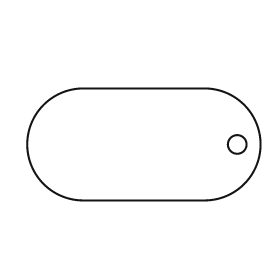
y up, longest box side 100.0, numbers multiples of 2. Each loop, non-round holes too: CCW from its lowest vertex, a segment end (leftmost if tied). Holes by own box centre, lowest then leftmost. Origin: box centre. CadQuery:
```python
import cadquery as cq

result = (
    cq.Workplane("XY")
    .moveTo(-26.0, -24.0)
    .lineTo(26.0, -24.0)
    .threePointArc((50.0, 0.0), (26.0, 24.0))
    .lineTo(-26.0, 24.0)
    .threePointArc((-50.0, 0.0), (-26.0, -24.0))
    .close()
    .moveTo(40.0, 0.0)
    .circle(4.0)
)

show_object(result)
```